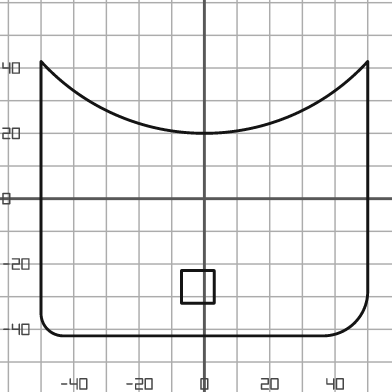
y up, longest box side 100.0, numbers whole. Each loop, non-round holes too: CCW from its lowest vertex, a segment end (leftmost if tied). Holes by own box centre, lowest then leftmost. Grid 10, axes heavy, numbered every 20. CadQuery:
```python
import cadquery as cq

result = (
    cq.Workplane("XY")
    .moveTo(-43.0, -42.0)
    .lineTo(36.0, -42.0)
    .threePointArc((46.0, -38.0), (50.0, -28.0))
    .lineTo(50.0, 42.0)
    .threePointArc((0.0, 20.0), (-50.0, 42.0))
    .lineTo(-50.0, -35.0)
    .threePointArc((-48.0, -40.0), (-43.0, -42.0))
    .close()
    .moveTo(-7.0, -32.0)
    .lineTo(3.0, -32.0)
    .lineTo(3.0, -22.0)
    .lineTo(-7.0, -22.0)
    .close()
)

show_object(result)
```